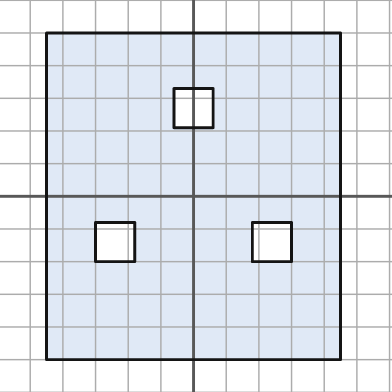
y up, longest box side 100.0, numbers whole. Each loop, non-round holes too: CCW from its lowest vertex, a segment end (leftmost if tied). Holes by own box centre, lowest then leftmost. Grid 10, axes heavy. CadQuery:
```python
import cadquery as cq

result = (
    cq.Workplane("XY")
    .moveTo(-45.0, -50.0)
    .lineTo(45.0, -50.0)
    .lineTo(45.0, 50.0)
    .lineTo(-45.0, 50.0)
    .close()
    .moveTo(-30.0, -20.0)
    .lineTo(-18.0, -20.0)
    .lineTo(-18.0, -8.0)
    .lineTo(-30.0, -8.0)
    .close()
    .moveTo(18.0, -20.0)
    .lineTo(30.0, -20.0)
    .lineTo(30.0, -8.0)
    .lineTo(18.0, -8.0)
    .close()
    .moveTo(-6.0, 21.0)
    .lineTo(6.0, 21.0)
    .lineTo(6.0, 33.0)
    .lineTo(-6.0, 33.0)
    .close()
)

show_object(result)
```